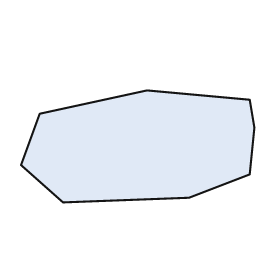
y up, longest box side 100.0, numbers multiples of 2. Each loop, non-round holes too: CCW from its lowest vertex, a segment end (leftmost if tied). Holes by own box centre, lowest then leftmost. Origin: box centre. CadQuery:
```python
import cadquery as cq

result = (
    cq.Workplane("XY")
    .moveTo(-32.0, -24.0)
    .lineTo(22.0, -22.0)
    .lineTo(48.0, -12.0)
    .lineTo(50.0, 8.0)
    .lineTo(48.0, 20.0)
    .lineTo(4.0, 24.0)
    .lineTo(-42.0, 14.0)
    .lineTo(-50.0, -8.0)
    .close()
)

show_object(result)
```